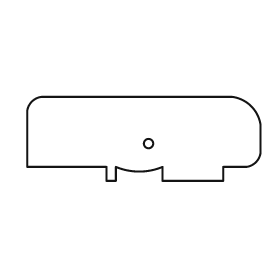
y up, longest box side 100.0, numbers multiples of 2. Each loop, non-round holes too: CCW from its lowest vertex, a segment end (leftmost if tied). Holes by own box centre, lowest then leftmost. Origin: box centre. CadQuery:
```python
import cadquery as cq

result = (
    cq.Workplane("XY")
    .moveTo(-16.0, -18.0)
    .lineTo(-12.0, -18.0)
    .lineTo(-12.0, -12.0)
    .threePointArc((-2.0, -14.0), (8.0, -12.0))
    .lineTo(8.0, -18.0)
    .lineTo(34.0, -18.0)
    .lineTo(34.0, -12.0)
    .lineTo(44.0, -12.0)
    .threePointArc((48.0, -10.0), (50.0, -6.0))
    .lineTo(50.0, 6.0)
    .threePointArc((46.0, 14.0), (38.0, 18.0))
    .lineTo(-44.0, 18.0)
    .threePointArc((-48.0, 16.0), (-50.0, 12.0))
    .lineTo(-50.0, -12.0)
    .lineTo(-16.0, -12.0)
    .close()
    .moveTo(2.0, -2.0)
    .circle(2.0)
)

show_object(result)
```